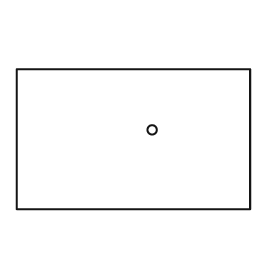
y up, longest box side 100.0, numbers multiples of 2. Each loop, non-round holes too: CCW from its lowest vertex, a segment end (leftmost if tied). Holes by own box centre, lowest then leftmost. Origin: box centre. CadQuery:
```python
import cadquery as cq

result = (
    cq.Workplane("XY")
    .moveTo(-50.0, -30.0)
    .lineTo(50.0, -30.0)
    .lineTo(50.0, 30.0)
    .lineTo(-50.0, 30.0)
    .close()
    .moveTo(8.0, 4.0)
    .circle(2.0)
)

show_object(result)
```